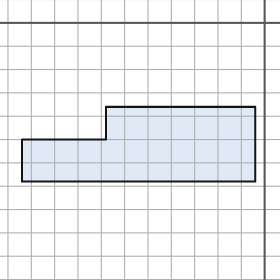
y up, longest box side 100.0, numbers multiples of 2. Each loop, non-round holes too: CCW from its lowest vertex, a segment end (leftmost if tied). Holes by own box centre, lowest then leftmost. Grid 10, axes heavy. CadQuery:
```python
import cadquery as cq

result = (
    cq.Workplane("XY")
    .moveTo(-104.0, -68.0)
    .lineTo(-4.0, -68.0)
    .lineTo(-4.0, -36.0)
    .lineTo(-68.0, -36.0)
    .lineTo(-68.0, -50.0)
    .lineTo(-104.0, -50.0)
    .close()
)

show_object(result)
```